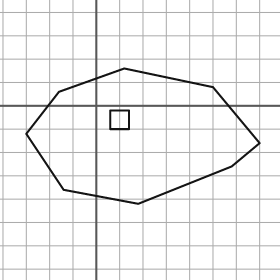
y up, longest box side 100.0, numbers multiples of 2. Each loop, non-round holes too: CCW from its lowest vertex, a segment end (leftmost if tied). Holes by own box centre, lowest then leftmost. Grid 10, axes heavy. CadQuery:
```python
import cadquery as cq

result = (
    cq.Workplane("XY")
    .moveTo(18.0, -42.0)
    .lineTo(58.0, -26.0)
    .lineTo(70.0, -16.0)
    .lineTo(50.0, 8.0)
    .lineTo(12.0, 16.0)
    .lineTo(-16.0, 6.0)
    .lineTo(-30.0, -12.0)
    .lineTo(-14.0, -36.0)
    .close()
    .moveTo(6.0, -10.0)
    .lineTo(14.0, -10.0)
    .lineTo(14.0, -2.0)
    .lineTo(6.0, -2.0)
    .close()
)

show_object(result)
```